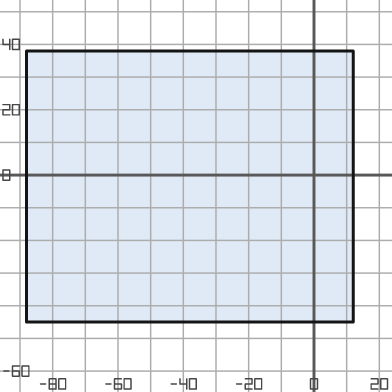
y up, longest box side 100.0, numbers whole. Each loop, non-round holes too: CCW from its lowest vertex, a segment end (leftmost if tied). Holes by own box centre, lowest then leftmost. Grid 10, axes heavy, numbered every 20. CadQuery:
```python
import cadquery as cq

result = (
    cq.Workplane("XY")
    .moveTo(-88.0, -45.0)
    .lineTo(12.0, -45.0)
    .lineTo(12.0, 38.0)
    .lineTo(-88.0, 38.0)
    .close()
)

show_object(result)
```